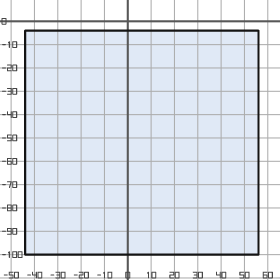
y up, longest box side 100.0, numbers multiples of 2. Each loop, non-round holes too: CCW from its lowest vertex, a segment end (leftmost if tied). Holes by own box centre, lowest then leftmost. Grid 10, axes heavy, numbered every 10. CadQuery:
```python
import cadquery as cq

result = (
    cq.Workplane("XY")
    .moveTo(-44.0, -100.0)
    .lineTo(56.0, -100.0)
    .lineTo(56.0, -4.0)
    .lineTo(-44.0, -4.0)
    .close()
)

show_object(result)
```